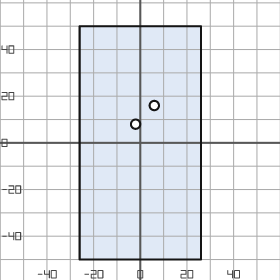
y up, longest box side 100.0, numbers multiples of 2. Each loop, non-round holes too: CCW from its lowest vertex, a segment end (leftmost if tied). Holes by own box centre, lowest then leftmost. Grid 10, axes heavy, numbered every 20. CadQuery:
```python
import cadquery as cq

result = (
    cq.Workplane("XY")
    .moveTo(-26.0, -50.0)
    .lineTo(26.0, -50.0)
    .lineTo(26.0, 50.0)
    .lineTo(-26.0, 50.0)
    .close()
    .moveTo(-2.0, 8.0)
    .circle(2.0)
    .moveTo(6.0, 16.0)
    .circle(2.0)
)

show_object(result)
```